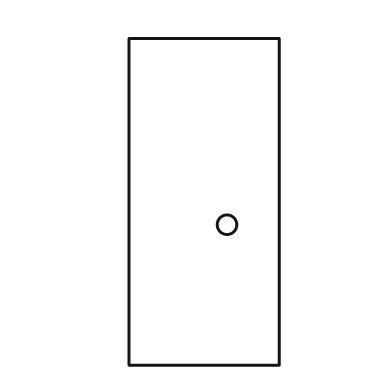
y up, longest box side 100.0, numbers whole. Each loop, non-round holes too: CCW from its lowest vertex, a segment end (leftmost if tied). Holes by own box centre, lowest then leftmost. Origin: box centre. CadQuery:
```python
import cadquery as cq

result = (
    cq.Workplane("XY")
    .moveTo(-23.0, -50.0)
    .lineTo(23.0, -50.0)
    .lineTo(23.0, 50.0)
    .lineTo(-23.0, 50.0)
    .close()
    .moveTo(7.0, -7.0)
    .circle(3.0)
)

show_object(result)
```